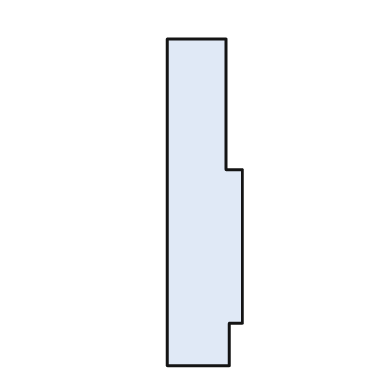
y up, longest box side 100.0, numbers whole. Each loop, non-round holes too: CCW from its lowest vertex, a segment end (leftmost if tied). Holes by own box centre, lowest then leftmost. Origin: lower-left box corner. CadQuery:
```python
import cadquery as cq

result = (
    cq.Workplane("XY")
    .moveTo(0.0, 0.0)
    .lineTo(19.0, 0.0)
    .lineTo(19.0, 13.0)
    .lineTo(23.0, 13.0)
    .lineTo(23.0, 60.0)
    .lineTo(18.0, 60.0)
    .lineTo(18.0, 100.0)
    .lineTo(0.0, 100.0)
    .close()
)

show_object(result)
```